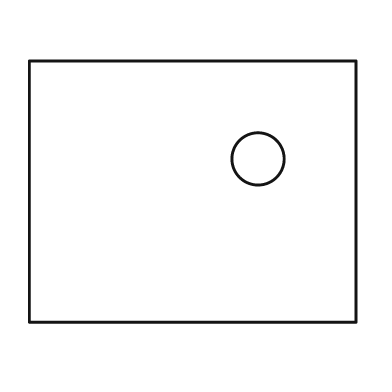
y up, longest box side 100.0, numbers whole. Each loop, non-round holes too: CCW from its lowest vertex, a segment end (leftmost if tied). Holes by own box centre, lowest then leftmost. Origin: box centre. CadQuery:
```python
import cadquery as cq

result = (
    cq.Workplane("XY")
    .moveTo(-50.0, -40.0)
    .lineTo(50.0, -40.0)
    .lineTo(50.0, 40.0)
    .lineTo(-50.0, 40.0)
    .close()
    .moveTo(20.0, 10.0)
    .circle(8.0)
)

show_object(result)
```